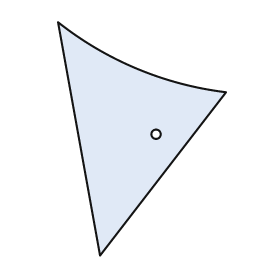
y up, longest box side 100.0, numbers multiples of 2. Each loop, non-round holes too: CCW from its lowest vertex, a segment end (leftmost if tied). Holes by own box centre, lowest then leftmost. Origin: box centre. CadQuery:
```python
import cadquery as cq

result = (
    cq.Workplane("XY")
    .moveTo(-18.0, -50.0)
    .lineTo(36.0, 20.0)
    .threePointArc((-2.0, 30.0), (-36.0, 50.0))
    .close()
    .moveTo(6.0, 2.0)
    .circle(2.0)
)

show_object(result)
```